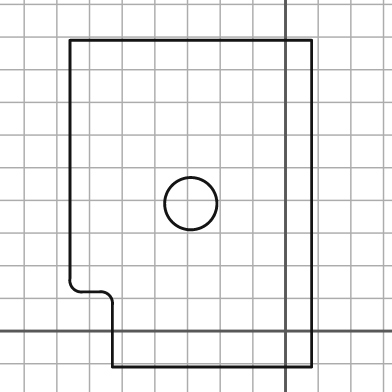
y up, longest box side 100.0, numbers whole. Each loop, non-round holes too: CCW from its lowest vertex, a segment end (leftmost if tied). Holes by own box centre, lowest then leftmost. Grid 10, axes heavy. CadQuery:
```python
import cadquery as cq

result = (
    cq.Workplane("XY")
    .moveTo(-53.0, -11.0)
    .lineTo(8.0, -11.0)
    .lineTo(8.0, 89.0)
    .lineTo(-66.0, 89.0)
    .lineTo(-66.0, 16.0)
    .threePointArc((-65.0, 13.0), (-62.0, 12.0))
    .lineTo(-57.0, 12.0)
    .threePointArc((-54.0, 11.0), (-53.0, 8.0))
    .close()
    .moveTo(-29.0, 39.0)
    .circle(8.0)
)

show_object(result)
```